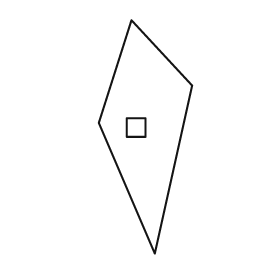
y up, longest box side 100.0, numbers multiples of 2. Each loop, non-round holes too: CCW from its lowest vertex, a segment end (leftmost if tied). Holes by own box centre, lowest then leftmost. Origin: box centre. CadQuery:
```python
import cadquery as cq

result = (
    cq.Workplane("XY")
    .moveTo(4.0, -50.0)
    .lineTo(20.0, 22.0)
    .lineTo(-6.0, 50.0)
    .lineTo(-20.0, 6.0)
    .close()
    .moveTo(-8.0, 0.0)
    .lineTo(0.0, 0.0)
    .lineTo(0.0, 8.0)
    .lineTo(-8.0, 8.0)
    .close()
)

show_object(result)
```